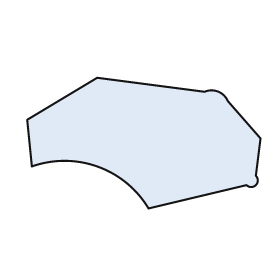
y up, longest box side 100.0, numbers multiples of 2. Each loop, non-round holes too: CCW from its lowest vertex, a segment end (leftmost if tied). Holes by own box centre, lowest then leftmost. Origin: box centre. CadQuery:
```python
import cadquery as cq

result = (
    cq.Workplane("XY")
    .moveTo(2.0, -28.0)
    .lineTo(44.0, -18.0)
    .threePointArc((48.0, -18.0), (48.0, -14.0))
    .lineTo(50.0, 2.0)
    .lineTo(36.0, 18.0)
    .threePointArc((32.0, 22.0), (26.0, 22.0))
    .lineTo(-20.0, 28.0)
    .lineTo(-50.0, 10.0)
    .lineTo(-48.0, -10.0)
    .threePointArc((-20.0, -10.0), (2.0, -28.0))
    .close()
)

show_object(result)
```